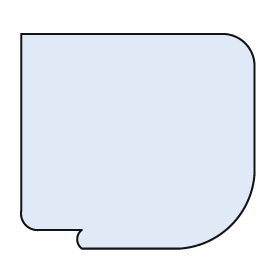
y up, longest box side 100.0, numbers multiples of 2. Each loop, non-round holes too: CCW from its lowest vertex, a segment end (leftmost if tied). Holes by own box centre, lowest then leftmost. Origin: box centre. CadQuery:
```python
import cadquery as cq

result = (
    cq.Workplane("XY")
    .moveTo(-24.0, -46.0)
    .lineTo(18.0, -46.0)
    .threePointArc((40.0, -36.0), (50.0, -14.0))
    .lineTo(50.0, 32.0)
    .threePointArc((46.0, 42.0), (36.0, 46.0))
    .lineTo(-50.0, 46.0)
    .lineTo(-50.0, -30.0)
    .threePointArc((-48.0, -36.0), (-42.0, -38.0))
    .lineTo(-24.0, -38.0)
    .threePointArc((-26.0, -42.0), (-24.0, -46.0))
    .close()
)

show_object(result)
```